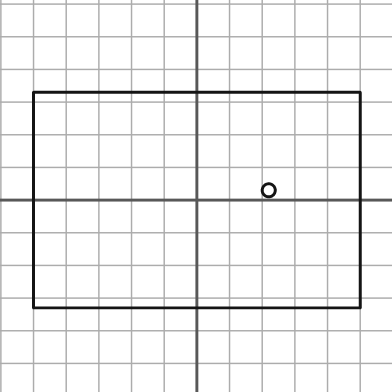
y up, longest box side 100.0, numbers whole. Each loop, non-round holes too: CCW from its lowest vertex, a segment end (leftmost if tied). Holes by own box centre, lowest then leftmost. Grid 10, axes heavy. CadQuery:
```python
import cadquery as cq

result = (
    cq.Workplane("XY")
    .moveTo(-50.0, -33.0)
    .lineTo(50.0, -33.0)
    .lineTo(50.0, 33.0)
    .lineTo(-50.0, 33.0)
    .close()
    .moveTo(22.0, 3.0)
    .circle(2.0)
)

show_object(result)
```